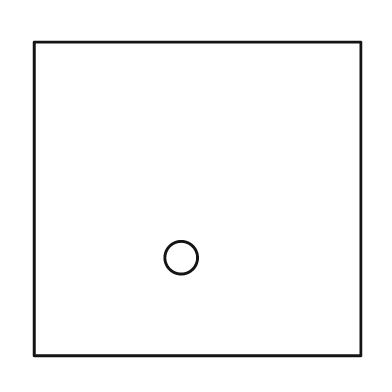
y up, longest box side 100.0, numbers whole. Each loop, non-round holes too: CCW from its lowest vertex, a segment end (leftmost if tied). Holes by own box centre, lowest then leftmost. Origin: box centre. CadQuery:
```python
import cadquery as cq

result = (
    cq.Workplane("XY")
    .moveTo(-50.0, -48.0)
    .lineTo(50.0, -48.0)
    .lineTo(50.0, 48.0)
    .lineTo(-50.0, 48.0)
    .close()
    .moveTo(-5.0, -18.0)
    .circle(5.0)
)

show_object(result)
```